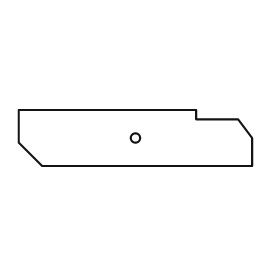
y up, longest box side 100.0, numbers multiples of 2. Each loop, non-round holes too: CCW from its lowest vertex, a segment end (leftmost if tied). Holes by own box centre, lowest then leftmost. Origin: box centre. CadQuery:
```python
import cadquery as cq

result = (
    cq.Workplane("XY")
    .moveTo(-40.0, -12.0)
    .lineTo(50.0, -12.0)
    .lineTo(50.0, 0.0)
    .lineTo(44.0, 8.0)
    .lineTo(26.0, 8.0)
    .lineTo(26.0, 12.0)
    .lineTo(-50.0, 12.0)
    .lineTo(-50.0, -2.0)
    .close()
    .moveTo(0.0, 0.0)
    .circle(2.0)
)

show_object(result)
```